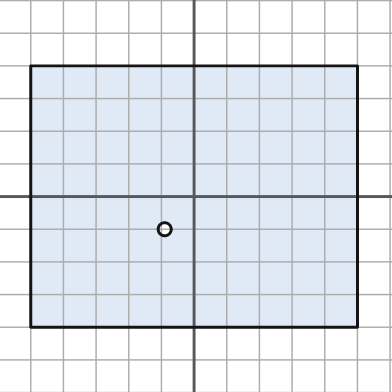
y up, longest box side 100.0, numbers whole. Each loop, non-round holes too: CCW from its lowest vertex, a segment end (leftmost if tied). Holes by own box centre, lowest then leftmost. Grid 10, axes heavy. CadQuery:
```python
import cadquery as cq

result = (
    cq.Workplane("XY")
    .moveTo(-50.0, -40.0)
    .lineTo(50.0, -40.0)
    .lineTo(50.0, 40.0)
    .lineTo(-50.0, 40.0)
    .close()
    .moveTo(-9.0, -10.0)
    .circle(2.0)
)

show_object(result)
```